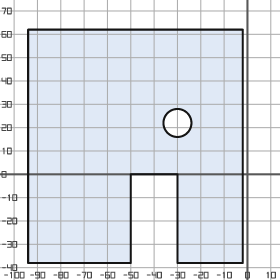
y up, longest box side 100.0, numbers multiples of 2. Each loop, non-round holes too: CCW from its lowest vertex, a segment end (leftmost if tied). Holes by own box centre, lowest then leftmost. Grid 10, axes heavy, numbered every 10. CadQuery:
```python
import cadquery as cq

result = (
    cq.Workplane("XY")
    .moveTo(-94.0, -38.0)
    .lineTo(-50.0, -38.0)
    .lineTo(-50.0, 0.0)
    .lineTo(-30.0, 0.0)
    .lineTo(-30.0, -38.0)
    .lineTo(-2.0, -38.0)
    .lineTo(-2.0, 62.0)
    .lineTo(-94.0, 62.0)
    .close()
    .moveTo(-30.0, 22.0)
    .circle(6.0)
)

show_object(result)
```